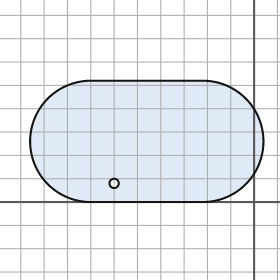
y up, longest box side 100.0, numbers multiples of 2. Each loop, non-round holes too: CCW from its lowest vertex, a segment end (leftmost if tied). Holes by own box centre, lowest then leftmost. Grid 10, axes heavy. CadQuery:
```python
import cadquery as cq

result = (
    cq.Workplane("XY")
    .moveTo(-70.0, 0.0)
    .lineTo(-22.0, 0.0)
    .threePointArc((4.0, 26.0), (-22.0, 52.0))
    .lineTo(-70.0, 52.0)
    .threePointArc((-96.0, 26.0), (-70.0, 0.0))
    .close()
    .moveTo(-60.0, 8.0)
    .circle(2.0)
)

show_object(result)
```